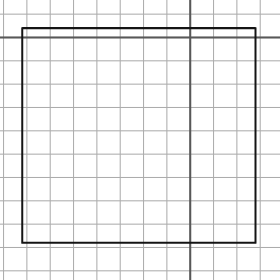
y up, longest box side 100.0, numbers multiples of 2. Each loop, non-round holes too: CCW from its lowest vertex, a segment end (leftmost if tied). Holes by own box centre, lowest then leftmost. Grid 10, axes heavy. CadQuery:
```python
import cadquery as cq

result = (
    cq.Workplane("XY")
    .moveTo(-72.0, -88.0)
    .lineTo(28.0, -88.0)
    .lineTo(28.0, 4.0)
    .lineTo(-72.0, 4.0)
    .close()
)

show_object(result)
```